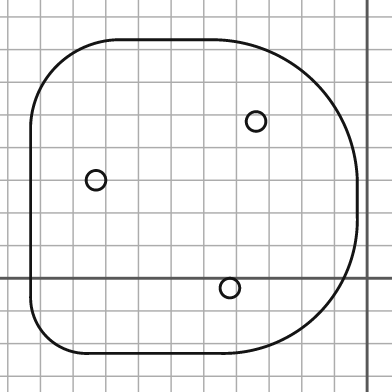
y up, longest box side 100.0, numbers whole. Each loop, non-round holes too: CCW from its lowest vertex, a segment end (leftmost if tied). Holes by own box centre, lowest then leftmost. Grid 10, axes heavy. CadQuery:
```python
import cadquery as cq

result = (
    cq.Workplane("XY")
    .moveTo(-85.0, -23.0)
    .lineTo(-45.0, -23.0)
    .threePointArc((-15.0, -11.0), (-3.0, 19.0))
    .lineTo(-3.0, 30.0)
    .threePointArc((-16.0, 60.0), (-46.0, 73.0))
    .lineTo(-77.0, 73.0)
    .threePointArc((-95.0, 65.0), (-103.0, 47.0))
    .lineTo(-103.0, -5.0)
    .threePointArc((-98.0, -18.0), (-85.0, -23.0))
    .close()
    .moveTo(-42.0, -3.0)
    .circle(3.0)
    .moveTo(-83.0, 30.0)
    .circle(3.0)
    .moveTo(-34.0, 48.0)
    .circle(3.0)
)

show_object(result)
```